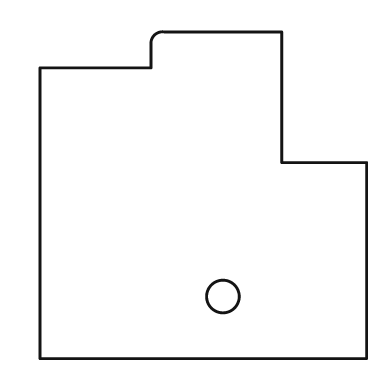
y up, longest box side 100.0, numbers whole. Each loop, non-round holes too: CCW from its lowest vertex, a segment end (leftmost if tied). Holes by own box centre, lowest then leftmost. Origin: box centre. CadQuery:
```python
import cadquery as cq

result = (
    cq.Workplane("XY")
    .moveTo(-50.0, -50.0)
    .lineTo(50.0, -50.0)
    .lineTo(50.0, 10.0)
    .lineTo(24.0, 10.0)
    .lineTo(24.0, 50.0)
    .lineTo(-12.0, 50.0)
    .threePointArc((-15.0, 49.0), (-16.0, 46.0))
    .lineTo(-16.0, 39.0)
    .lineTo(-50.0, 39.0)
    .close()
    .moveTo(6.0, -31.0)
    .circle(5.0)
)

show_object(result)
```